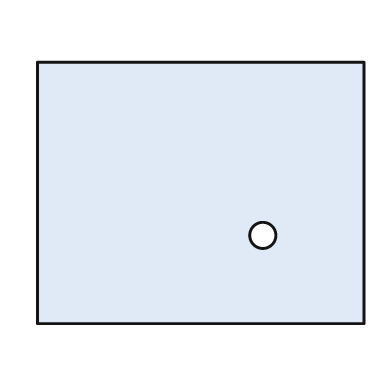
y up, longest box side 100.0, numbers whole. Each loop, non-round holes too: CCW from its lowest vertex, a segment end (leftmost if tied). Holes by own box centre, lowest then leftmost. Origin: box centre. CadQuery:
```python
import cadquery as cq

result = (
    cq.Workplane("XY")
    .moveTo(-50.0, -40.0)
    .lineTo(50.0, -40.0)
    .lineTo(50.0, 40.0)
    .lineTo(-50.0, 40.0)
    .close()
    .moveTo(19.0, -13.0)
    .circle(4.0)
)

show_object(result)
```